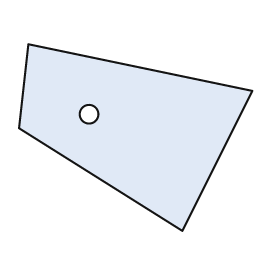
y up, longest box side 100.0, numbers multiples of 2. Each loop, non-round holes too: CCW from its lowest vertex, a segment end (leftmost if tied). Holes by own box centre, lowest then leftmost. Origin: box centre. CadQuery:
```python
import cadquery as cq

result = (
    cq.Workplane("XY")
    .moveTo(20.0, -40.0)
    .lineTo(50.0, 20.0)
    .lineTo(-46.0, 40.0)
    .lineTo(-50.0, 4.0)
    .close()
    .moveTo(-20.0, 10.0)
    .circle(4.0)
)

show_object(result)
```